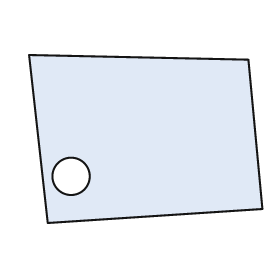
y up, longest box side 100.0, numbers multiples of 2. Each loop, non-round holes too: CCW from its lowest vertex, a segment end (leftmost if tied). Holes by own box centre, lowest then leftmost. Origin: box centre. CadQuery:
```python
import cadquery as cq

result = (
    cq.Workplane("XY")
    .moveTo(-42.0, -36.0)
    .lineTo(50.0, -30.0)
    .lineTo(44.0, 34.0)
    .lineTo(-50.0, 36.0)
    .close()
    .moveTo(-32.0, -16.0)
    .circle(8.0)
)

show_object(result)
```